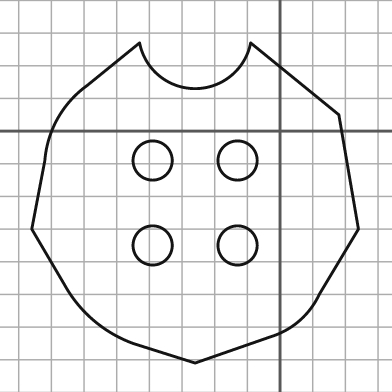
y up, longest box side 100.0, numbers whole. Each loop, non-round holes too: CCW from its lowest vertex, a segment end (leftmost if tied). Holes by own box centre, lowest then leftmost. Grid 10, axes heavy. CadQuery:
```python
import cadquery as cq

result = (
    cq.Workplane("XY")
    .moveTo(-26.0, -71.0)
    .lineTo(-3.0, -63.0)
    .threePointArc((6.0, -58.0), (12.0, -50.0))
    .lineTo(24.0, -30.0)
    .lineTo(18.0, 5.0)
    .lineTo(-9.0, 27.0)
    .threePointArc((-26.0, 13.0), (-43.0, 27.0))
    .lineTo(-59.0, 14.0)
    .threePointArc((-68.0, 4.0), (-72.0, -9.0))
    .lineTo(-76.0, -30.0)
    .lineTo(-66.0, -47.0)
    .threePointArc((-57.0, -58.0), (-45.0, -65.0))
    .close()
    .moveTo(-39.0, -35.0)
    .circle(6.0)
    .moveTo(-13.0, -35.0)
    .circle(6.0)
    .moveTo(-39.0, -9.0)
    .circle(6.0)
    .moveTo(-13.0, -9.0)
    .circle(6.0)
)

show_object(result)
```